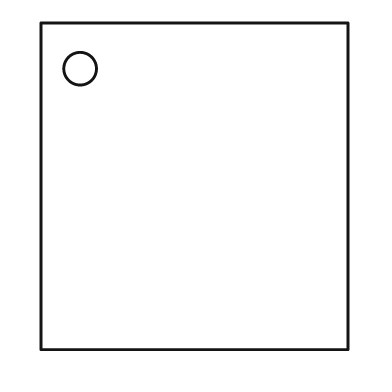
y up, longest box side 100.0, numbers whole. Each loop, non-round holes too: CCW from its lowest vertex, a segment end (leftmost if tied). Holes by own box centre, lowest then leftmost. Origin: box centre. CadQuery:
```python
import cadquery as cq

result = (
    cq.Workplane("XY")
    .moveTo(-47.0, -50.0)
    .lineTo(47.0, -50.0)
    .lineTo(47.0, 50.0)
    .lineTo(-47.0, 50.0)
    .close()
    .moveTo(-35.0, 36.0)
    .circle(5.0)
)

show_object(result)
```